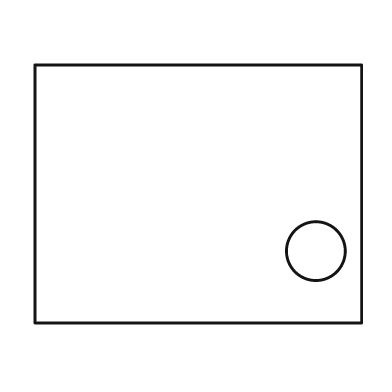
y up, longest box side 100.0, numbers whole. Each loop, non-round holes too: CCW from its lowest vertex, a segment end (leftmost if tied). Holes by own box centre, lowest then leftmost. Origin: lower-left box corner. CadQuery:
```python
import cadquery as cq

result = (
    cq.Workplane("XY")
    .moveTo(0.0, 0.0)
    .lineTo(100.0, 0.0)
    .lineTo(100.0, 79.0)
    .lineTo(0.0, 79.0)
    .close()
    .moveTo(86.0, 22.0)
    .circle(9.0)
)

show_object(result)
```